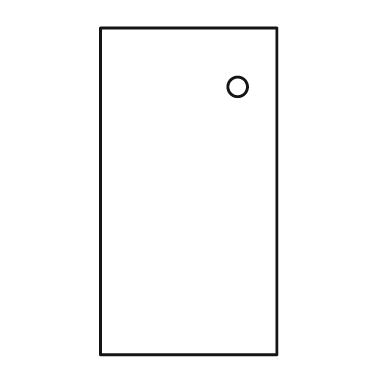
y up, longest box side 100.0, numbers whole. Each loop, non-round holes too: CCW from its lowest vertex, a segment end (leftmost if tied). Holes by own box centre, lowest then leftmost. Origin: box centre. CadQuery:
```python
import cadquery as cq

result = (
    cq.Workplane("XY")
    .moveTo(-27.0, -50.0)
    .lineTo(27.0, -50.0)
    .lineTo(27.0, 50.0)
    .lineTo(-27.0, 50.0)
    .close()
    .moveTo(15.0, 32.0)
    .circle(3.0)
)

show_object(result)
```